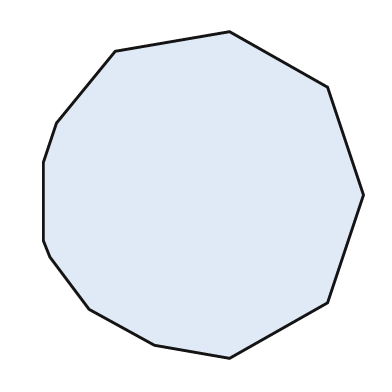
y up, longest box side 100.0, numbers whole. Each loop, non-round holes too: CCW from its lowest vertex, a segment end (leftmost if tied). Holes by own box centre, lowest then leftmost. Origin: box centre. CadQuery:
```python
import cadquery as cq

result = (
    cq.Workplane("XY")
    .moveTo(8.0, -50.0)
    .lineTo(38.0, -33.0)
    .lineTo(49.0, 0.0)
    .lineTo(38.0, 33.0)
    .lineTo(8.0, 50.0)
    .lineTo(-27.0, 44.0)
    .lineTo(-45.0, 22.0)
    .lineTo(-49.0, 10.0)
    .lineTo(-49.0, -14.0)
    .lineTo(-47.0, -19.0)
    .lineTo(-35.0, -35.0)
    .lineTo(-15.0, -46.0)
    .close()
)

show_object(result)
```